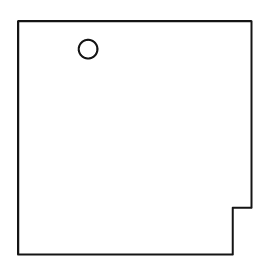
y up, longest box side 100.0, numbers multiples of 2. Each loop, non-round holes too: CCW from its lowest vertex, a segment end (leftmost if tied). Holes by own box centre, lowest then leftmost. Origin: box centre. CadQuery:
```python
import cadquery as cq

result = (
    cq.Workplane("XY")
    .moveTo(-50.0, -50.0)
    .lineTo(42.0, -50.0)
    .lineTo(42.0, -30.0)
    .lineTo(50.0, -30.0)
    .lineTo(50.0, 50.0)
    .lineTo(-50.0, 50.0)
    .close()
    .moveTo(-20.0, 38.0)
    .circle(4.0)
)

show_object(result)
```